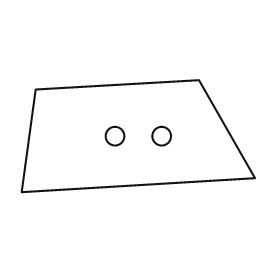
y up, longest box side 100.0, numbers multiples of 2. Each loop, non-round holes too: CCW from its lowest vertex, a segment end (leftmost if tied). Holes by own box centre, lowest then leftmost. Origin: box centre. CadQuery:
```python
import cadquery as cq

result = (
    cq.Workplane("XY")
    .moveTo(-50.0, -24.0)
    .lineTo(50.0, -18.0)
    .lineTo(26.0, 24.0)
    .lineTo(-44.0, 20.0)
    .close()
    .moveTo(-10.0, 0.0)
    .circle(4.0)
    .moveTo(10.0, 0.0)
    .circle(4.0)
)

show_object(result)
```